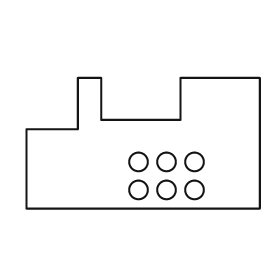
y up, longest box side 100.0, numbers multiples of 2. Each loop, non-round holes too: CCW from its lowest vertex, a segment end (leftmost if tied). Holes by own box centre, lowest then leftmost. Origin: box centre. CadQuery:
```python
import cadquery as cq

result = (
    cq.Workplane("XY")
    .moveTo(-50.0, -28.0)
    .lineTo(50.0, -28.0)
    .lineTo(50.0, 28.0)
    .lineTo(16.0, 28.0)
    .lineTo(16.0, 10.0)
    .lineTo(-18.0, 10.0)
    .lineTo(-18.0, 28.0)
    .lineTo(-28.0, 28.0)
    .lineTo(-28.0, 6.0)
    .lineTo(-50.0, 6.0)
    .close()
    .moveTo(-2.0, -20.0)
    .circle(4.0)
    .moveTo(10.0, -20.0)
    .circle(4.0)
    .moveTo(22.0, -20.0)
    .circle(4.0)
    .moveTo(-2.0, -8.0)
    .circle(4.0)
    .moveTo(10.0, -8.0)
    .circle(4.0)
    .moveTo(22.0, -8.0)
    .circle(4.0)
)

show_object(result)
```